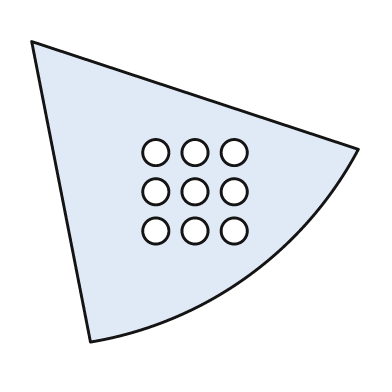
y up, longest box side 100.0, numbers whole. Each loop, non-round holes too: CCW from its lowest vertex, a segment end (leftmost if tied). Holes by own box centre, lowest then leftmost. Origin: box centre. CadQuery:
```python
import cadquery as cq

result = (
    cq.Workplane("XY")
    .moveTo(-32.0, -46.0)
    .threePointArc((16.0, -26.0), (50.0, 13.0))
    .lineTo(-50.0, 46.0)
    .close()
    .moveTo(-12.0, -12.0)
    .circle(4.0)
    .moveTo(0.0, -12.0)
    .circle(4.0)
    .moveTo(12.0, -12.0)
    .circle(4.0)
    .moveTo(-12.0, 0.0)
    .circle(4.0)
    .moveTo(0.0, 0.0)
    .circle(4.0)
    .moveTo(12.0, 0.0)
    .circle(4.0)
    .moveTo(-12.0, 12.0)
    .circle(4.0)
    .moveTo(0.0, 12.0)
    .circle(4.0)
    .moveTo(12.0, 12.0)
    .circle(4.0)
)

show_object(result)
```